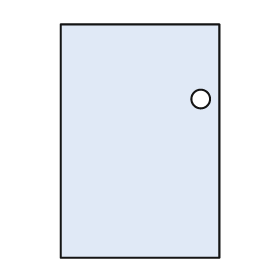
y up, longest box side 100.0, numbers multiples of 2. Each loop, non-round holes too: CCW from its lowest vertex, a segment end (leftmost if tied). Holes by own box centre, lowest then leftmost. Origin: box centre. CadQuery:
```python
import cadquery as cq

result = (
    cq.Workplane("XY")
    .moveTo(-34.0, -50.0)
    .lineTo(34.0, -50.0)
    .lineTo(34.0, 50.0)
    .lineTo(-34.0, 50.0)
    .close()
    .moveTo(26.0, 18.0)
    .circle(4.0)
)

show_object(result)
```